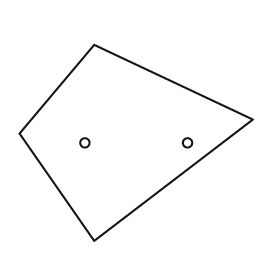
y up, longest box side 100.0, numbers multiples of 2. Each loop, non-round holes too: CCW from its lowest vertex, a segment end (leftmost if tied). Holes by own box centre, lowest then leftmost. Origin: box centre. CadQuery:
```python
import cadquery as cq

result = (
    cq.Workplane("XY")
    .moveTo(-18.0, -42.0)
    .lineTo(50.0, 10.0)
    .lineTo(-18.0, 42.0)
    .lineTo(-50.0, 4.0)
    .close()
    .moveTo(-22.0, 0.0)
    .circle(2.0)
    .moveTo(22.0, 0.0)
    .circle(2.0)
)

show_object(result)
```